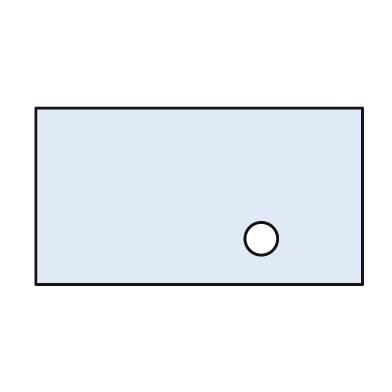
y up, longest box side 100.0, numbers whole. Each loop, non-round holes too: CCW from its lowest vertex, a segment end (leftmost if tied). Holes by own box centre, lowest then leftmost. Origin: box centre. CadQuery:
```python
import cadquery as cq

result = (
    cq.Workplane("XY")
    .moveTo(-50.0, -27.0)
    .lineTo(50.0, -27.0)
    .lineTo(50.0, 27.0)
    .lineTo(-50.0, 27.0)
    .close()
    .moveTo(19.0, -13.0)
    .circle(5.0)
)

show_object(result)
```